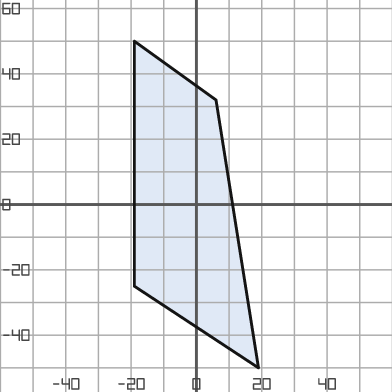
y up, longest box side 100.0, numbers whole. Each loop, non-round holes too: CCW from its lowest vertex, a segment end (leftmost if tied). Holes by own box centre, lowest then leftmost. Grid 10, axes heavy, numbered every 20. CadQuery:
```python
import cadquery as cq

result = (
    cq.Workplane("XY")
    .moveTo(19.0, -50.0)
    .lineTo(6.0, 32.0)
    .lineTo(-19.0, 50.0)
    .lineTo(-19.0, -25.0)
    .close()
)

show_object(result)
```